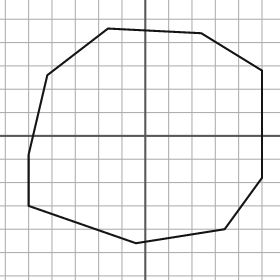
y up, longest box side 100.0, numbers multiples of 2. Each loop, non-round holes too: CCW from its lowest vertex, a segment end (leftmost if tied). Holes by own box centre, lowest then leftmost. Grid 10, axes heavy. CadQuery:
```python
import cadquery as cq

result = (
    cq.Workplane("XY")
    .moveTo(-4.0, -46.0)
    .lineTo(34.0, -40.0)
    .lineTo(50.0, -18.0)
    .lineTo(50.0, 28.0)
    .lineTo(24.0, 44.0)
    .lineTo(-16.0, 46.0)
    .lineTo(-42.0, 26.0)
    .lineTo(-50.0, -8.0)
    .lineTo(-50.0, -30.0)
    .close()
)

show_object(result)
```